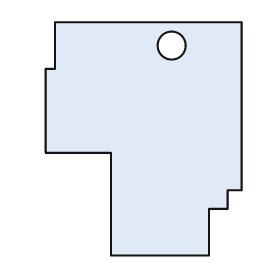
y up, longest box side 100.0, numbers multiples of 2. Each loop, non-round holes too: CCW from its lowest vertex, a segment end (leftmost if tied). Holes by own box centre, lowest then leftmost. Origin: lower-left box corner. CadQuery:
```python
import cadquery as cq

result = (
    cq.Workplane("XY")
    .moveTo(28.0, 0.0)
    .lineTo(70.0, 0.0)
    .lineTo(70.0, 20.0)
    .lineTo(78.0, 20.0)
    .lineTo(78.0, 28.0)
    .lineTo(84.0, 28.0)
    .lineTo(84.0, 100.0)
    .lineTo(4.0, 100.0)
    .lineTo(4.0, 80.0)
    .lineTo(0.0, 80.0)
    .lineTo(0.0, 44.0)
    .lineTo(28.0, 44.0)
    .close()
    .moveTo(54.0, 90.0)
    .circle(6.0)
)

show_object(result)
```